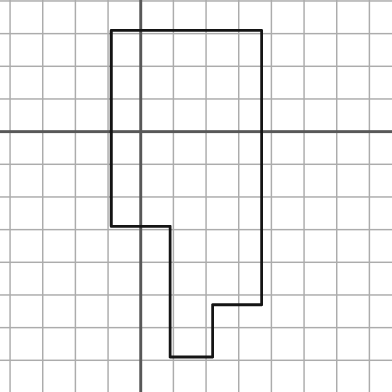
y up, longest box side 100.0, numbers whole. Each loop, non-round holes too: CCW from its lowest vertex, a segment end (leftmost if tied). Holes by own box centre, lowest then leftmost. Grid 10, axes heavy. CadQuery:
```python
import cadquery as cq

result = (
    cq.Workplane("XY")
    .moveTo(9.0, -69.0)
    .lineTo(22.0, -69.0)
    .lineTo(22.0, -53.0)
    .lineTo(37.0, -53.0)
    .lineTo(37.0, 31.0)
    .lineTo(-9.0, 31.0)
    .lineTo(-9.0, -29.0)
    .lineTo(9.0, -29.0)
    .close()
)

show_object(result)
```